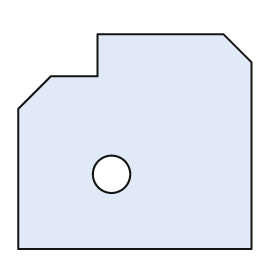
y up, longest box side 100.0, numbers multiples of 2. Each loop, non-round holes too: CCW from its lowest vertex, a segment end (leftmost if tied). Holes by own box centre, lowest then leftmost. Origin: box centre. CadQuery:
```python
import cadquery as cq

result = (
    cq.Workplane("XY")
    .moveTo(-50.0, -46.0)
    .lineTo(50.0, -46.0)
    .lineTo(50.0, 34.0)
    .lineTo(38.0, 46.0)
    .lineTo(-16.0, 46.0)
    .lineTo(-16.0, 28.0)
    .lineTo(-36.0, 28.0)
    .lineTo(-50.0, 14.0)
    .close()
    .moveTo(-10.0, -14.0)
    .circle(8.0)
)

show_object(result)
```